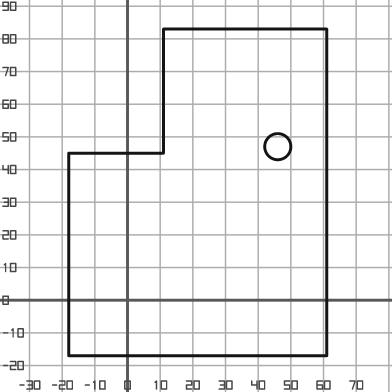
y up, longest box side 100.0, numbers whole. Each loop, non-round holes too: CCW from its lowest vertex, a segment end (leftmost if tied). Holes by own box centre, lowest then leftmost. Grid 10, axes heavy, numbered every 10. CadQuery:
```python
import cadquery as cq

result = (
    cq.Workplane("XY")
    .moveTo(-18.0, -17.0)
    .lineTo(61.0, -17.0)
    .lineTo(61.0, 83.0)
    .lineTo(11.0, 83.0)
    .lineTo(11.0, 45.0)
    .lineTo(-18.0, 45.0)
    .close()
    .moveTo(46.0, 47.0)
    .circle(4.0)
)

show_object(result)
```